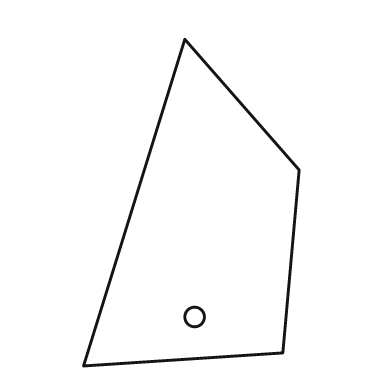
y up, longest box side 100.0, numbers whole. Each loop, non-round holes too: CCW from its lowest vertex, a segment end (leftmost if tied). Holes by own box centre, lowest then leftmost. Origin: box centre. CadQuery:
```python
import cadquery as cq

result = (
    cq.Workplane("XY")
    .moveTo(-33.0, -50.0)
    .lineTo(28.0, -46.0)
    .lineTo(33.0, 10.0)
    .lineTo(-2.0, 50.0)
    .close()
    .moveTo(1.0, -35.0)
    .circle(3.0)
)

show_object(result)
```